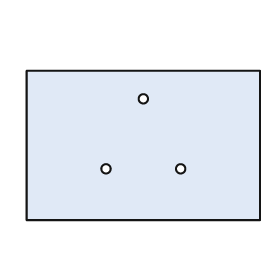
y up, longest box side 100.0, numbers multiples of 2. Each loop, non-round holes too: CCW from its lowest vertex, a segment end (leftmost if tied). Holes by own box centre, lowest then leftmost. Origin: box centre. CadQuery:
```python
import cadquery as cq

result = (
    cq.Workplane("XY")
    .moveTo(-50.0, -32.0)
    .lineTo(50.0, -32.0)
    .lineTo(50.0, 32.0)
    .lineTo(-50.0, 32.0)
    .close()
    .moveTo(-16.0, -10.0)
    .circle(2.0)
    .moveTo(16.0, -10.0)
    .circle(2.0)
    .moveTo(0.0, 20.0)
    .circle(2.0)
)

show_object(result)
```